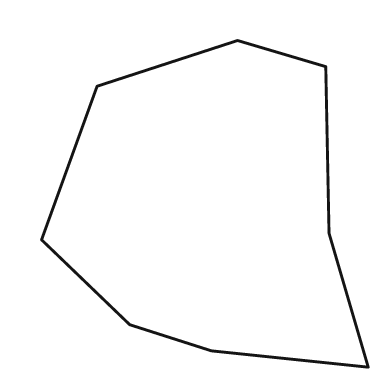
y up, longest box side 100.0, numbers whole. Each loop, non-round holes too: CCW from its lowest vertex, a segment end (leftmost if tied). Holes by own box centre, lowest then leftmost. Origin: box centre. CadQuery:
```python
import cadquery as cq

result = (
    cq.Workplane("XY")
    .moveTo(50.0, -50.0)
    .lineTo(38.0, -9.0)
    .lineTo(37.0, 42.0)
    .lineTo(10.0, 50.0)
    .lineTo(-33.0, 36.0)
    .lineTo(-50.0, -11.0)
    .lineTo(-23.0, -37.0)
    .lineTo(2.0, -45.0)
    .close()
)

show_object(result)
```